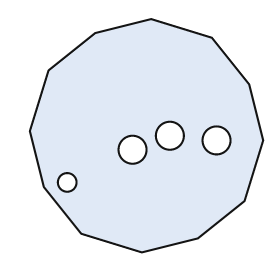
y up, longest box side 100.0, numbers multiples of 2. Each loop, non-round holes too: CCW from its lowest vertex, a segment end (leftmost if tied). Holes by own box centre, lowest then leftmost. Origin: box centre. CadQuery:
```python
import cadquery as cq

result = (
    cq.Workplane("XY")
    .moveTo(-2.0, -50.0)
    .lineTo(22.0, -44.0)
    .lineTo(42.0, -28.0)
    .lineTo(50.0, -2.0)
    .lineTo(44.0, 22.0)
    .lineTo(28.0, 42.0)
    .lineTo(2.0, 50.0)
    .lineTo(-22.0, 44.0)
    .lineTo(-42.0, 28.0)
    .lineTo(-50.0, 2.0)
    .lineTo(-44.0, -22.0)
    .lineTo(-28.0, -42.0)
    .close()
    .moveTo(-34.0, -20.0)
    .circle(4.0)
    .moveTo(-6.0, -6.0)
    .circle(6.0)
    .moveTo(30.0, -2.0)
    .circle(6.0)
    .moveTo(10.0, 0.0)
    .circle(6.0)
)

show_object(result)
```